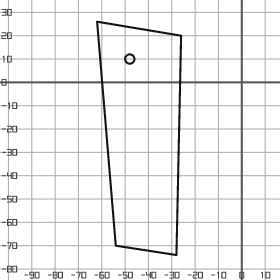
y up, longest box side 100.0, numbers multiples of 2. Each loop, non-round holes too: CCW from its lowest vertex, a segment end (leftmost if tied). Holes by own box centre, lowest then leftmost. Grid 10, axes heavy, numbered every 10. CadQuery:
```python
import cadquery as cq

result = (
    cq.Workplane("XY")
    .moveTo(-28.0, -74.0)
    .lineTo(-26.0, 20.0)
    .lineTo(-62.0, 26.0)
    .lineTo(-54.0, -70.0)
    .close()
    .moveTo(-48.0, 10.0)
    .circle(2.0)
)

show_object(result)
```